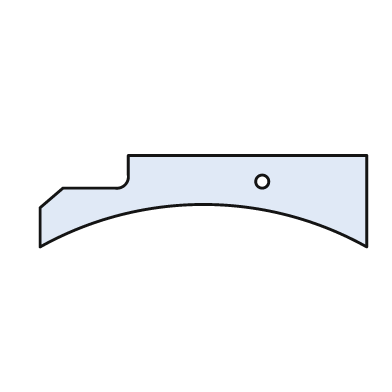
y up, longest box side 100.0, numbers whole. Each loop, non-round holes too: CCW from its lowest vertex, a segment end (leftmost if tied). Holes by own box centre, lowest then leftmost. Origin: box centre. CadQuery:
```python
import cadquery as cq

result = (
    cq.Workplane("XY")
    .moveTo(-50.0, -14.0)
    .threePointArc((0.0, -1.0), (50.0, -14.0))
    .lineTo(50.0, 14.0)
    .lineTo(-23.0, 14.0)
    .lineTo(-23.0, 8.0)
    .threePointArc((-24.0, 5.0), (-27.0, 4.0))
    .lineTo(-43.0, 4.0)
    .lineTo(-50.0, -2.0)
    .close()
    .moveTo(18.0, 6.0)
    .circle(2.0)
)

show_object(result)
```